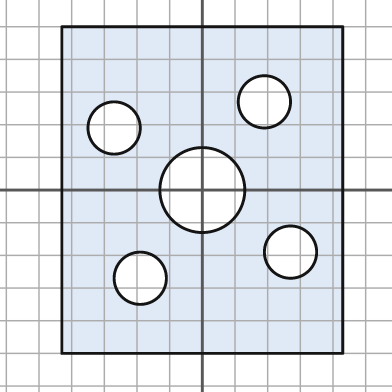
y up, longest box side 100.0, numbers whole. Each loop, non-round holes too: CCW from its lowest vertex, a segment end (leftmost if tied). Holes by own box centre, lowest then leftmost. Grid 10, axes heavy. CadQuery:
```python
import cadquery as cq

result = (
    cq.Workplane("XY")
    .moveTo(-43.0, -50.0)
    .lineTo(43.0, -50.0)
    .lineTo(43.0, 50.0)
    .lineTo(-43.0, 50.0)
    .close()
    .moveTo(-19.0, -27.0)
    .circle(8.0)
    .moveTo(27.0, -19.0)
    .circle(8.0)
    .moveTo(0.0, 0.0)
    .circle(13.0)
    .moveTo(-27.0, 19.0)
    .circle(8.0)
    .moveTo(19.0, 27.0)
    .circle(8.0)
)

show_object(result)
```